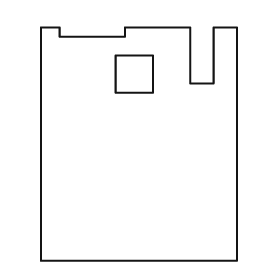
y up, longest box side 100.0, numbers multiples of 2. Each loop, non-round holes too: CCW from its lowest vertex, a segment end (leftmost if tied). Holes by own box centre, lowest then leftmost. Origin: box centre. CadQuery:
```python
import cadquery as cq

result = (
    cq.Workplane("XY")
    .moveTo(-42.0, -50.0)
    .lineTo(42.0, -50.0)
    .lineTo(42.0, 50.0)
    .lineTo(32.0, 50.0)
    .lineTo(32.0, 26.0)
    .lineTo(22.0, 26.0)
    .lineTo(22.0, 50.0)
    .lineTo(-6.0, 50.0)
    .lineTo(-6.0, 46.0)
    .lineTo(-34.0, 46.0)
    .lineTo(-34.0, 50.0)
    .lineTo(-42.0, 50.0)
    .close()
    .moveTo(-10.0, 22.0)
    .lineTo(6.0, 22.0)
    .lineTo(6.0, 38.0)
    .lineTo(-10.0, 38.0)
    .close()
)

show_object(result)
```